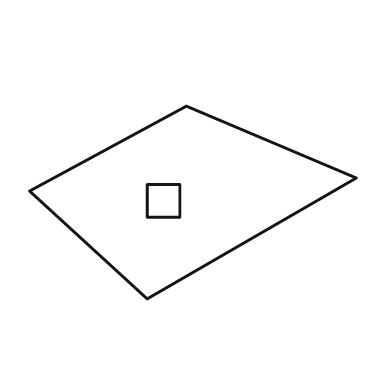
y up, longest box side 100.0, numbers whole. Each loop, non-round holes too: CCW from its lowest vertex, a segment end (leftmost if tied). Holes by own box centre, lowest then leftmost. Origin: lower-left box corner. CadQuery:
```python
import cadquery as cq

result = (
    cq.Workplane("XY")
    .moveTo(36.0, 0.0)
    .lineTo(100.0, 37.0)
    .lineTo(48.0, 59.0)
    .lineTo(0.0, 33.0)
    .close()
    .moveTo(36.0, 25.0)
    .lineTo(46.0, 25.0)
    .lineTo(46.0, 35.0)
    .lineTo(36.0, 35.0)
    .close()
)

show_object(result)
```